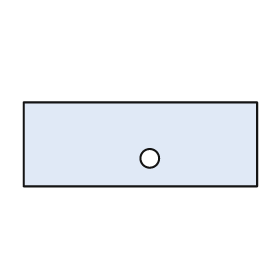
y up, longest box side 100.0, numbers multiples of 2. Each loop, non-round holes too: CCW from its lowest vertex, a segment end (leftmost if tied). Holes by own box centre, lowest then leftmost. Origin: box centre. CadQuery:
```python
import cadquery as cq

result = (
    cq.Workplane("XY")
    .moveTo(-50.0, -18.0)
    .lineTo(50.0, -18.0)
    .lineTo(50.0, 18.0)
    .lineTo(-50.0, 18.0)
    .close()
    .moveTo(4.0, -6.0)
    .circle(4.0)
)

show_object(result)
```